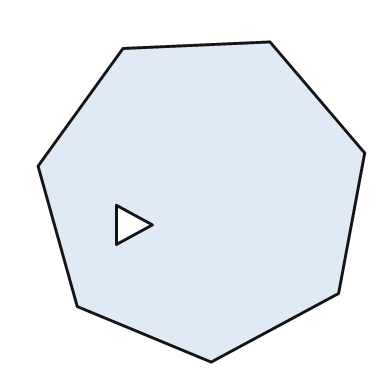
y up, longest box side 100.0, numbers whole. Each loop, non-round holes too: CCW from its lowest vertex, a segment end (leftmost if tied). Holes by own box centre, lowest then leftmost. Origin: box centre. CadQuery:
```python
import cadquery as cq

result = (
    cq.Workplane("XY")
    .moveTo(3.0, -49.0)
    .lineTo(42.0, -28.0)
    .lineTo(50.0, 15.0)
    .lineTo(21.0, 49.0)
    .lineTo(-24.0, 47.0)
    .lineTo(-50.0, 11.0)
    .lineTo(-38.0, -32.0)
    .close()
    .moveTo(-26.0, -13.0)
    .lineTo(-15.0, -7.0)
    .lineTo(-26.0, -1.0)
    .close()
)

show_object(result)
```